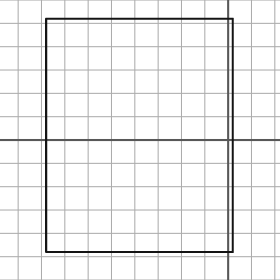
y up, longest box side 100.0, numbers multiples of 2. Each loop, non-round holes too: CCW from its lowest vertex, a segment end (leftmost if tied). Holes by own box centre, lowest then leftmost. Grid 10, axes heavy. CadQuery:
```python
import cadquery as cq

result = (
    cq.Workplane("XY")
    .moveTo(-78.0, -48.0)
    .lineTo(2.0, -48.0)
    .lineTo(2.0, 52.0)
    .lineTo(-78.0, 52.0)
    .close()
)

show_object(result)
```